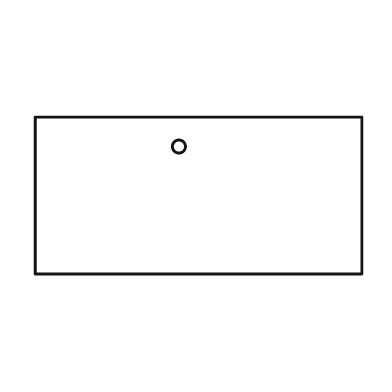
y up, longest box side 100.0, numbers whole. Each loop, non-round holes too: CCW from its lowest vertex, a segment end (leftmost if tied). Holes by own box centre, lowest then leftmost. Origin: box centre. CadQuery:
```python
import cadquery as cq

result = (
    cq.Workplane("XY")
    .moveTo(-50.0, -24.0)
    .lineTo(50.0, -24.0)
    .lineTo(50.0, 24.0)
    .lineTo(-50.0, 24.0)
    .close()
    .moveTo(-6.0, 15.0)
    .circle(2.0)
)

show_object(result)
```